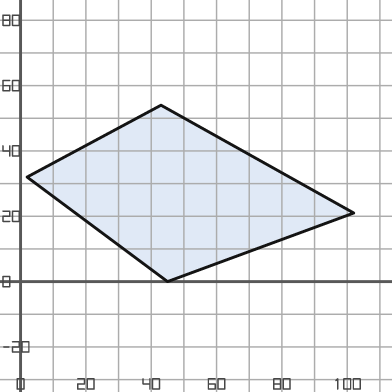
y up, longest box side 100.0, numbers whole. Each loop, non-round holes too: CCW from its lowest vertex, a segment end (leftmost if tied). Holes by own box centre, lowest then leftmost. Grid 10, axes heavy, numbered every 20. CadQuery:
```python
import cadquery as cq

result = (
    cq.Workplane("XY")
    .moveTo(45.0, 0.0)
    .lineTo(102.0, 21.0)
    .lineTo(43.0, 54.0)
    .lineTo(2.0, 32.0)
    .close()
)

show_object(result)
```